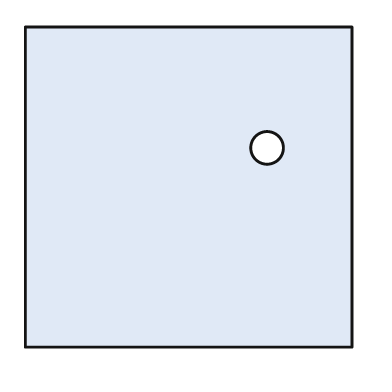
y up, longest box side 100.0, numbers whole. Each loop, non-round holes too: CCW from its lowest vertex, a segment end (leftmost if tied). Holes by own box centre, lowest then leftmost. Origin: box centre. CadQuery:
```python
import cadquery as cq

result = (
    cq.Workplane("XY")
    .moveTo(-50.0, -49.0)
    .lineTo(50.0, -49.0)
    .lineTo(50.0, 49.0)
    .lineTo(-50.0, 49.0)
    .close()
    .moveTo(24.0, 12.0)
    .circle(5.0)
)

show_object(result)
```